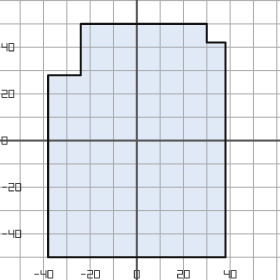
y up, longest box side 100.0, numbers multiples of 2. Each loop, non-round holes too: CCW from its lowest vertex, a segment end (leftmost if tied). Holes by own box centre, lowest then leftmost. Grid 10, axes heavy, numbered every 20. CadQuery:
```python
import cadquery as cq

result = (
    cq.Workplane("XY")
    .moveTo(-38.0, -50.0)
    .lineTo(38.0, -50.0)
    .lineTo(38.0, 42.0)
    .lineTo(30.0, 42.0)
    .lineTo(30.0, 50.0)
    .lineTo(-24.0, 50.0)
    .lineTo(-24.0, 28.0)
    .lineTo(-38.0, 28.0)
    .close()
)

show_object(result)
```